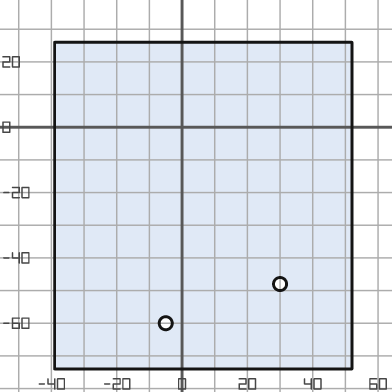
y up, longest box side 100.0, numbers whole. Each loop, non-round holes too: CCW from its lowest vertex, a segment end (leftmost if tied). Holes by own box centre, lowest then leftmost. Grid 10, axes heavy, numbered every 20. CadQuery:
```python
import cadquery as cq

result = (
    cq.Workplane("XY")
    .moveTo(-39.0, -74.0)
    .lineTo(52.0, -74.0)
    .lineTo(52.0, 26.0)
    .lineTo(-39.0, 26.0)
    .close()
    .moveTo(-5.0, -60.0)
    .circle(2.0)
    .moveTo(30.0, -48.0)
    .circle(2.0)
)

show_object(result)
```